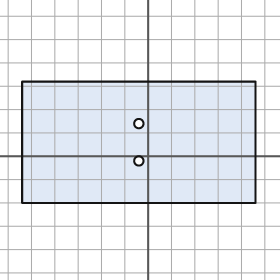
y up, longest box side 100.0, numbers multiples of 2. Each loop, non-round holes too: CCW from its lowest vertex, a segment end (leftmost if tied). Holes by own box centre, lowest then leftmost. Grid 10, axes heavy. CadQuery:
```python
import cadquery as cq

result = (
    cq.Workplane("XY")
    .moveTo(-54.0, -20.0)
    .lineTo(46.0, -20.0)
    .lineTo(46.0, 32.0)
    .lineTo(-54.0, 32.0)
    .close()
    .moveTo(-4.0, -2.0)
    .circle(2.0)
    .moveTo(-4.0, 14.0)
    .circle(2.0)
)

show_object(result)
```